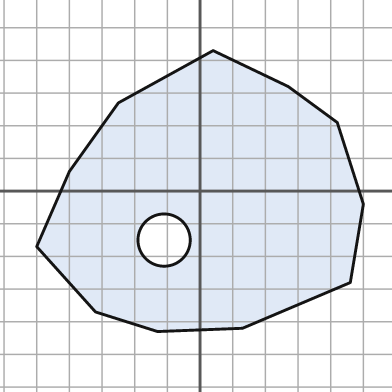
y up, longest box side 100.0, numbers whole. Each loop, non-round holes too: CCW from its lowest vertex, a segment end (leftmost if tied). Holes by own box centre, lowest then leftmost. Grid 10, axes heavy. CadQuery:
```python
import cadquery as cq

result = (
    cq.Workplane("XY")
    .moveTo(-13.0, -43.0)
    .lineTo(13.0, -42.0)
    .lineTo(46.0, -28.0)
    .lineTo(50.0, -4.0)
    .lineTo(42.0, 21.0)
    .lineTo(27.0, 32.0)
    .lineTo(4.0, 43.0)
    .lineTo(-25.0, 27.0)
    .lineTo(-40.0, 6.0)
    .lineTo(-50.0, -17.0)
    .lineTo(-32.0, -37.0)
    .close()
    .moveTo(-11.0, -15.0)
    .circle(8.0)
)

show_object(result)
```